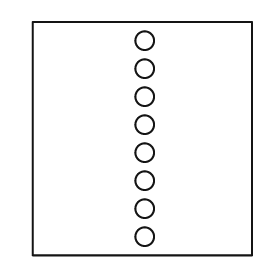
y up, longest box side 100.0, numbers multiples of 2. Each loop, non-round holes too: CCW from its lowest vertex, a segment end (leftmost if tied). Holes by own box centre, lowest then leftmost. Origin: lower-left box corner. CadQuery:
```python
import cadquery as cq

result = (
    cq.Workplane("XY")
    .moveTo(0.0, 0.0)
    .lineTo(94.0, 0.0)
    .lineTo(94.0, 100.0)
    .lineTo(0.0, 100.0)
    .close()
    .moveTo(48.0, 8.0)
    .circle(4.0)
    .moveTo(48.0, 20.0)
    .circle(4.0)
    .moveTo(48.0, 32.0)
    .circle(4.0)
    .moveTo(48.0, 44.0)
    .circle(4.0)
    .moveTo(48.0, 56.0)
    .circle(4.0)
    .moveTo(48.0, 68.0)
    .circle(4.0)
    .moveTo(48.0, 80.0)
    .circle(4.0)
    .moveTo(48.0, 92.0)
    .circle(4.0)
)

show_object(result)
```